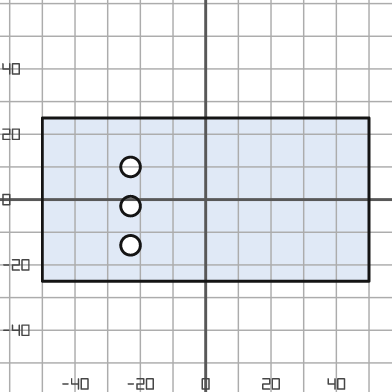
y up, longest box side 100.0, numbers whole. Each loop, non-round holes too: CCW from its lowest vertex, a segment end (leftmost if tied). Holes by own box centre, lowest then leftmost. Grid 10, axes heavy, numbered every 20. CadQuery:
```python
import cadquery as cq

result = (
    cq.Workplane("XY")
    .moveTo(-50.0, -25.0)
    .lineTo(50.0, -25.0)
    .lineTo(50.0, 25.0)
    .lineTo(-50.0, 25.0)
    .close()
    .moveTo(-23.0, -14.0)
    .circle(3.0)
    .moveTo(-23.0, -2.0)
    .circle(3.0)
    .moveTo(-23.0, 10.0)
    .circle(3.0)
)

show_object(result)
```